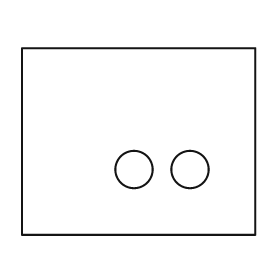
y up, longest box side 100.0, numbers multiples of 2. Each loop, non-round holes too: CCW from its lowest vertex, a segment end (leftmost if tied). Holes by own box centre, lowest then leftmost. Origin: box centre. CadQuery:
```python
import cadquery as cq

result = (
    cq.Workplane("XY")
    .moveTo(-50.0, -40.0)
    .lineTo(50.0, -40.0)
    .lineTo(50.0, 40.0)
    .lineTo(-50.0, 40.0)
    .close()
    .moveTo(-2.0, -12.0)
    .circle(8.0)
    .moveTo(22.0, -12.0)
    .circle(8.0)
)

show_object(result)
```